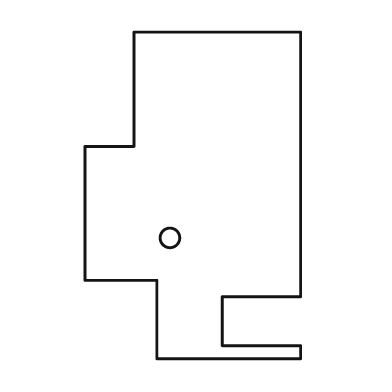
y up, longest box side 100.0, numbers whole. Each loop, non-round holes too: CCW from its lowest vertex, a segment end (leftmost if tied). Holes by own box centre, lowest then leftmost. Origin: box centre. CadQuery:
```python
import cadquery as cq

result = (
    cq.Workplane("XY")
    .moveTo(-11.0, -50.0)
    .lineTo(33.0, -50.0)
    .lineTo(33.0, -46.0)
    .lineTo(9.0, -46.0)
    .lineTo(9.0, -31.0)
    .lineTo(33.0, -31.0)
    .lineTo(33.0, 50.0)
    .lineTo(-18.0, 50.0)
    .lineTo(-18.0, 15.0)
    .lineTo(-33.0, 15.0)
    .lineTo(-33.0, -26.0)
    .lineTo(-11.0, -26.0)
    .close()
    .moveTo(-7.0, -13.0)
    .circle(3.0)
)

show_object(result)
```